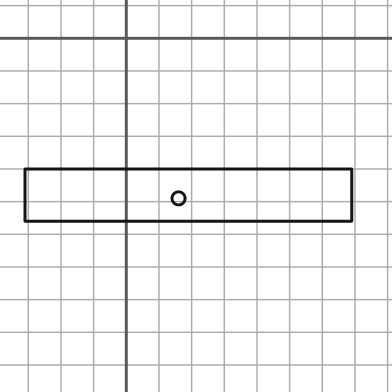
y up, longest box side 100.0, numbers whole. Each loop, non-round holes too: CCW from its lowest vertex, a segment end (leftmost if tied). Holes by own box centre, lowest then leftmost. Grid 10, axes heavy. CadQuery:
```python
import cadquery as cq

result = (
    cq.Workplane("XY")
    .moveTo(-31.0, -56.0)
    .lineTo(69.0, -56.0)
    .lineTo(69.0, -40.0)
    .lineTo(-31.0, -40.0)
    .close()
    .moveTo(16.0, -49.0)
    .circle(2.0)
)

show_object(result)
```